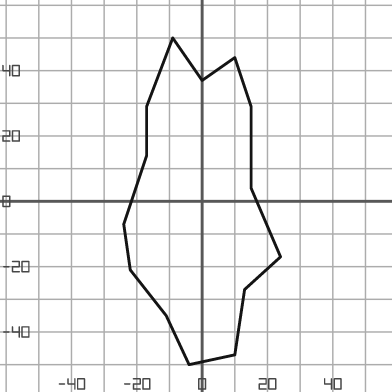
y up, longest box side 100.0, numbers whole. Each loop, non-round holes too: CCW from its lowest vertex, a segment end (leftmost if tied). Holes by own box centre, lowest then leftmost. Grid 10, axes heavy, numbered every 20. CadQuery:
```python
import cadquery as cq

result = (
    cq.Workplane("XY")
    .moveTo(-4.0, -50.0)
    .lineTo(10.0, -47.0)
    .lineTo(13.0, -27.0)
    .lineTo(24.0, -17.0)
    .lineTo(15.0, 4.0)
    .lineTo(15.0, 29.0)
    .lineTo(10.0, 44.0)
    .lineTo(0.0, 37.0)
    .lineTo(-9.0, 50.0)
    .lineTo(-17.0, 29.0)
    .lineTo(-17.0, 14.0)
    .lineTo(-24.0, -7.0)
    .lineTo(-22.0, -21.0)
    .lineTo(-11.0, -35.0)
    .close()
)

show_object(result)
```